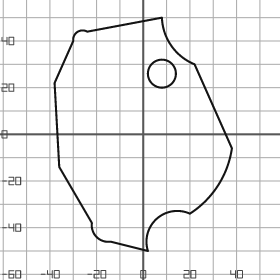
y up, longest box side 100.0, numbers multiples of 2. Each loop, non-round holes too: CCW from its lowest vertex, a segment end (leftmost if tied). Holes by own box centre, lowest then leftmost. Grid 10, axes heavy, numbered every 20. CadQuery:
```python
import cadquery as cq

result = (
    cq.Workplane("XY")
    .moveTo(2.0, -50.0)
    .threePointArc((6.0, -36.0), (20.0, -34.0))
    .threePointArc((32.0, -22.0), (38.0, -6.0))
    .lineTo(22.0, 30.0)
    .threePointArc((12.0, 38.0), (8.0, 50.0))
    .lineTo(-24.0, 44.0)
    .threePointArc((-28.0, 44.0), (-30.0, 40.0))
    .lineTo(-38.0, 22.0)
    .lineTo(-36.0, -14.0)
    .lineTo(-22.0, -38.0)
    .threePointArc((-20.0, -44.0), (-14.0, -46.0))
    .close()
    .moveTo(8.0, 26.0)
    .circle(6.0)
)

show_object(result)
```